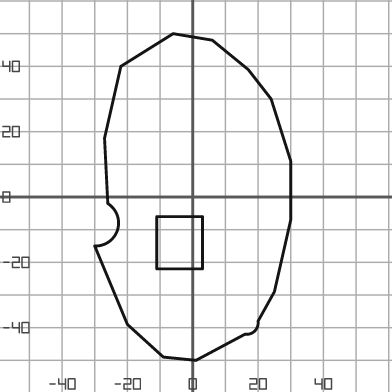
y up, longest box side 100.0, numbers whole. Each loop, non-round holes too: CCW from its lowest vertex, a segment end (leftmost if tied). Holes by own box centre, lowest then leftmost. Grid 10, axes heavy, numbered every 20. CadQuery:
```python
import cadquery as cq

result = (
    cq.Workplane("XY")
    .moveTo(1.0, -50.0)
    .lineTo(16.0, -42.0)
    .threePointArc((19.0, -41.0), (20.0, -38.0))
    .lineTo(25.0, -29.0)
    .lineTo(30.0, -7.0)
    .lineTo(30.0, 11.0)
    .lineTo(24.0, 30.0)
    .lineTo(17.0, 39.0)
    .lineTo(6.0, 48.0)
    .lineTo(-6.0, 50.0)
    .lineTo(-22.0, 40.0)
    .lineTo(-27.0, 18.0)
    .lineTo(-26.0, -2.0)
    .threePointArc((-23.0, -10.0), (-30.0, -15.0))
    .lineTo(-20.0, -39.0)
    .lineTo(-9.0, -49.0)
    .close()
    .moveTo(-11.0, -22.0)
    .lineTo(3.0, -22.0)
    .lineTo(3.0, -6.0)
    .lineTo(-11.0, -6.0)
    .close()
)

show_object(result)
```